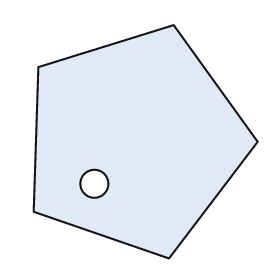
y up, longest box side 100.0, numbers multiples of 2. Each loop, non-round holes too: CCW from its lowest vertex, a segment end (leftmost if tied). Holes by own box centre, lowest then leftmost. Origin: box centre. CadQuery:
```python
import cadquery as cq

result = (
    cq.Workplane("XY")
    .moveTo(10.0, -50.0)
    .lineTo(48.0, 0.0)
    .lineTo(12.0, 50.0)
    .lineTo(-46.0, 32.0)
    .lineTo(-48.0, -30.0)
    .close()
    .moveTo(-22.0, -18.0)
    .circle(6.0)
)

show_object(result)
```